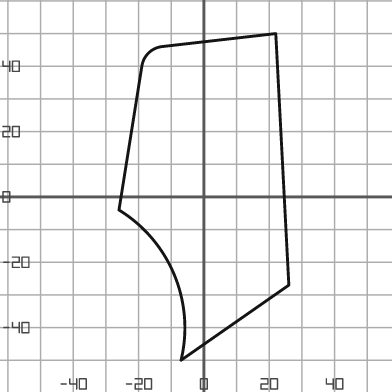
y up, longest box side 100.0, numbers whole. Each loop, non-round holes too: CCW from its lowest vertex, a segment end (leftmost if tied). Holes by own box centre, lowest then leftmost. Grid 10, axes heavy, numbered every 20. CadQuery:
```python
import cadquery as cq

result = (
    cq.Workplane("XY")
    .moveTo(-7.0, -50.0)
    .lineTo(26.0, -27.0)
    .lineTo(22.0, 50.0)
    .lineTo(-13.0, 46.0)
    .threePointArc((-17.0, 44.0), (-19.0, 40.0))
    .lineTo(-26.0, -4.0)
    .threePointArc((-9.0, -24.0), (-7.0, -50.0))
    .close()
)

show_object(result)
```